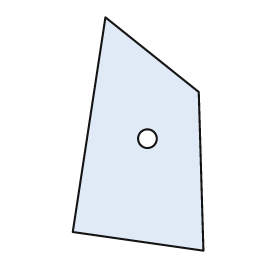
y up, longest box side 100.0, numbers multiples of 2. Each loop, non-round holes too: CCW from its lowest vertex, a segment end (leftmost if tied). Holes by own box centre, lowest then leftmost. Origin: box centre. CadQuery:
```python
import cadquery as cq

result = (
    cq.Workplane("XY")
    .moveTo(28.0, -50.0)
    .lineTo(26.0, 18.0)
    .lineTo(-14.0, 50.0)
    .lineTo(-28.0, -42.0)
    .close()
    .moveTo(4.0, -2.0)
    .circle(4.0)
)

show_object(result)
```